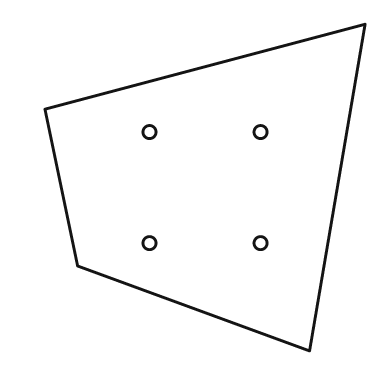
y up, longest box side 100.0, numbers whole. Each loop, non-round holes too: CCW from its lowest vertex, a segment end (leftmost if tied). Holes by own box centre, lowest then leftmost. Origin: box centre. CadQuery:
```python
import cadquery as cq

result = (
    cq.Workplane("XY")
    .moveTo(32.0, -50.0)
    .lineTo(49.0, 50.0)
    .lineTo(-49.0, 24.0)
    .lineTo(-39.0, -24.0)
    .close()
    .moveTo(-17.0, -17.0)
    .circle(2.0)
    .moveTo(17.0, -17.0)
    .circle(2.0)
    .moveTo(-17.0, 17.0)
    .circle(2.0)
    .moveTo(17.0, 17.0)
    .circle(2.0)
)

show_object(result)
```